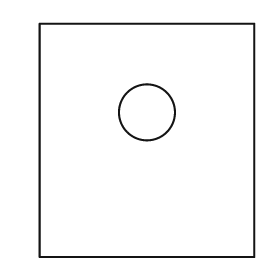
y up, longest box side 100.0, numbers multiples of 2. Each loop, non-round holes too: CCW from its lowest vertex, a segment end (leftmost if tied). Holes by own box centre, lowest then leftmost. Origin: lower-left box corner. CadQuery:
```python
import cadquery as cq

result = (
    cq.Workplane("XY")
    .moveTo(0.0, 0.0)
    .lineTo(92.0, 0.0)
    .lineTo(92.0, 100.0)
    .lineTo(0.0, 100.0)
    .close()
    .moveTo(46.0, 62.0)
    .circle(12.0)
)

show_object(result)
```